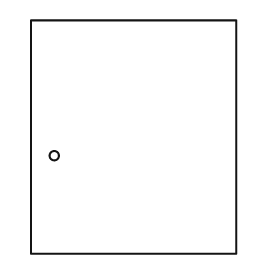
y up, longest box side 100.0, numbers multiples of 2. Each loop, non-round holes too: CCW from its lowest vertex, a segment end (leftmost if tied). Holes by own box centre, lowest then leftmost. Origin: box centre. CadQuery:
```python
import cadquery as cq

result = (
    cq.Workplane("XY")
    .moveTo(-44.0, -50.0)
    .lineTo(44.0, -50.0)
    .lineTo(44.0, 50.0)
    .lineTo(-44.0, 50.0)
    .close()
    .moveTo(-34.0, -8.0)
    .circle(2.0)
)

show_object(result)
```